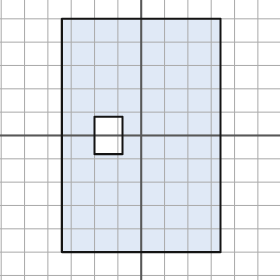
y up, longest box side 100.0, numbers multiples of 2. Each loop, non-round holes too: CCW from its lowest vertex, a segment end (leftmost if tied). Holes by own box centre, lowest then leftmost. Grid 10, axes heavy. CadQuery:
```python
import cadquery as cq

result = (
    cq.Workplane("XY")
    .moveTo(-34.0, -50.0)
    .lineTo(34.0, -50.0)
    .lineTo(34.0, 50.0)
    .lineTo(-34.0, 50.0)
    .close()
    .moveTo(-20.0, -8.0)
    .lineTo(-8.0, -8.0)
    .lineTo(-8.0, 8.0)
    .lineTo(-20.0, 8.0)
    .close()
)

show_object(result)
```